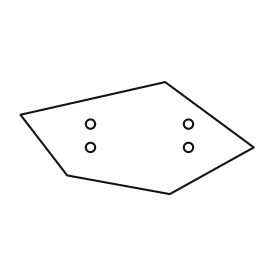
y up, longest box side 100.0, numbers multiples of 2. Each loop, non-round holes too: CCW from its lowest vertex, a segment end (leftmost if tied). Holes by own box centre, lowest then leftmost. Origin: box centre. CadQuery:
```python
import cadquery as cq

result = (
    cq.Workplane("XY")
    .moveTo(14.0, -24.0)
    .lineTo(50.0, -4.0)
    .lineTo(12.0, 24.0)
    .lineTo(-50.0, 10.0)
    .lineTo(-30.0, -16.0)
    .close()
    .moveTo(-20.0, -4.0)
    .circle(2.0)
    .moveTo(22.0, -4.0)
    .circle(2.0)
    .moveTo(-20.0, 6.0)
    .circle(2.0)
    .moveTo(22.0, 6.0)
    .circle(2.0)
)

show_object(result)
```